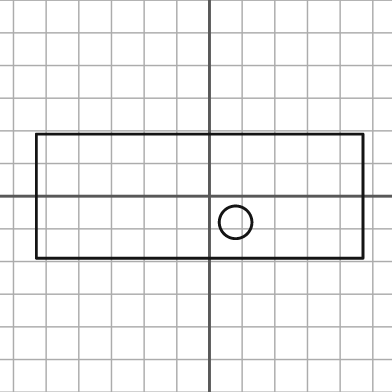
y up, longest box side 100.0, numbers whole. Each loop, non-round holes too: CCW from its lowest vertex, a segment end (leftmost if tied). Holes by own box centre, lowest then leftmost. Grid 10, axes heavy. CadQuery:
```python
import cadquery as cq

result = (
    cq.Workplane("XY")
    .moveTo(-53.0, -19.0)
    .lineTo(47.0, -19.0)
    .lineTo(47.0, 19.0)
    .lineTo(-53.0, 19.0)
    .close()
    .moveTo(8.0, -8.0)
    .circle(5.0)
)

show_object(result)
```